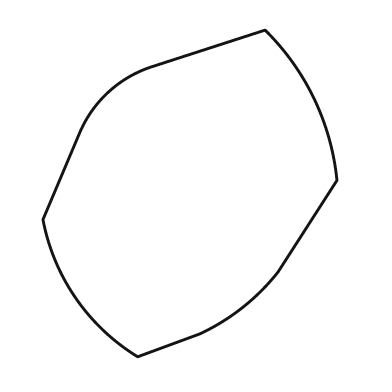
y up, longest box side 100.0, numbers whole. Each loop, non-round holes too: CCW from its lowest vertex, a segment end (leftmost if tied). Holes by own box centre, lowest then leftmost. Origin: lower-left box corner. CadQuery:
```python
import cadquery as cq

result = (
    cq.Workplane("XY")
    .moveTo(29.0, 0.0)
    .lineTo(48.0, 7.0)
    .threePointArc((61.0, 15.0), (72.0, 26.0))
    .lineTo(90.0, 54.0)
    .threePointArc((83.0, 79.0), (68.0, 100.0))
    .lineTo(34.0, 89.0)
    .threePointArc((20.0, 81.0), (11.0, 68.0))
    .lineTo(0.0, 42.0)
    .threePointArc((10.0, 18.0), (29.0, 0.0))
    .close()
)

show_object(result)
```